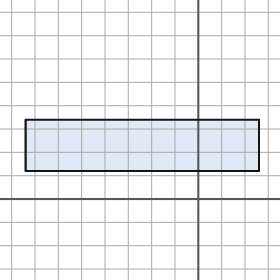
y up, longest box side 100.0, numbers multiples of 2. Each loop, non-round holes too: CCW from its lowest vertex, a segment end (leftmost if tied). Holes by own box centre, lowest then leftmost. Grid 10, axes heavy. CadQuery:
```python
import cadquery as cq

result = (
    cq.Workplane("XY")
    .moveTo(-74.0, 12.0)
    .lineTo(26.0, 12.0)
    .lineTo(26.0, 34.0)
    .lineTo(-74.0, 34.0)
    .close()
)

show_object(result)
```